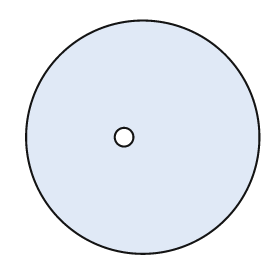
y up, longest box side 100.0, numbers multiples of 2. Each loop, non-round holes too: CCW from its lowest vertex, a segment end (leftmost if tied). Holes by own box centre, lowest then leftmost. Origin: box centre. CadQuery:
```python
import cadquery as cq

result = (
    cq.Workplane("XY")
    .moveTo(0.0, 0.0)
    .circle(50.0)
    .moveTo(-8.0, 0.0)
    .circle(4.0)
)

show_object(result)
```